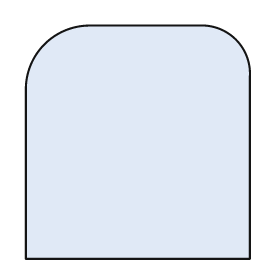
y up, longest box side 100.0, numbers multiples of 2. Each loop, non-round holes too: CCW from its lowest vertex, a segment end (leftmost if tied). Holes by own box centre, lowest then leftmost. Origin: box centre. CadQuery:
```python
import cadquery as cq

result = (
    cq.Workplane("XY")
    .moveTo(-48.0, -50.0)
    .lineTo(48.0, -50.0)
    .lineTo(48.0, 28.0)
    .threePointArc((42.0, 44.0), (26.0, 50.0))
    .lineTo(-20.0, 50.0)
    .threePointArc((-40.0, 42.0), (-48.0, 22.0))
    .close()
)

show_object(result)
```